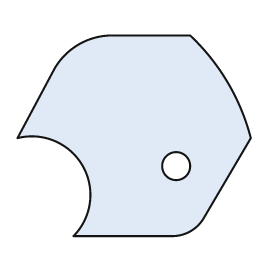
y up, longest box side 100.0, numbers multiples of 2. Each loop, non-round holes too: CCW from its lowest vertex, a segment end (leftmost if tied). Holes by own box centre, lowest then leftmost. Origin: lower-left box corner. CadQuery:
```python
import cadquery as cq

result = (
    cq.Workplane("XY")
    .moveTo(24.0, 0.0)
    .lineTo(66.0, 0.0)
    .threePointArc((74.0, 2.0), (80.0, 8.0))
    .lineTo(100.0, 42.0)
    .threePointArc((90.0, 66.0), (74.0, 86.0))
    .lineTo(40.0, 86.0)
    .threePointArc((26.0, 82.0), (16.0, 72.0))
    .lineTo(0.0, 42.0)
    .threePointArc((28.0, 30.0), (24.0, 0.0))
    .close()
    .moveTo(68.0, 30.0)
    .circle(6.0)
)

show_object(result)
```